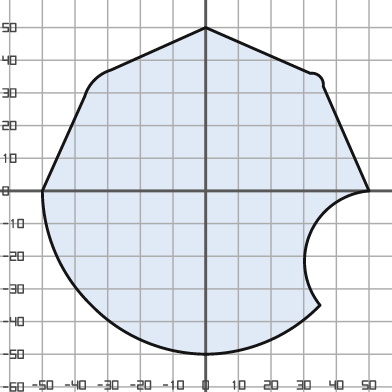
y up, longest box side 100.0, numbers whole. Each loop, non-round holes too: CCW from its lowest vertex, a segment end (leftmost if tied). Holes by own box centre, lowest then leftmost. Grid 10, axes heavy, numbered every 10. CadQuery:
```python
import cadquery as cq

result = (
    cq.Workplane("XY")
    .moveTo(0.0, -50.0)
    .threePointArc((19.0, -46.0), (35.0, -35.0))
    .threePointArc((32.0, -13.0), (50.0, 0.0))
    .lineTo(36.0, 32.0)
    .threePointArc((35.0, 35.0), (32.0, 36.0))
    .lineTo(0.0, 50.0)
    .lineTo(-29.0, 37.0)
    .threePointArc((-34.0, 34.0), (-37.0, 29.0))
    .lineTo(-50.0, 0.0)
    .threePointArc((-46.0, -19.0), (-35.0, -35.0))
    .threePointArc((-19.0, -46.0), (0.0, -50.0))
    .close()
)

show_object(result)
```